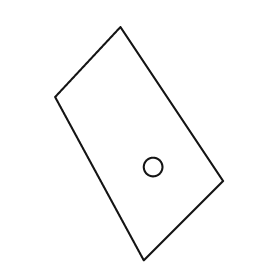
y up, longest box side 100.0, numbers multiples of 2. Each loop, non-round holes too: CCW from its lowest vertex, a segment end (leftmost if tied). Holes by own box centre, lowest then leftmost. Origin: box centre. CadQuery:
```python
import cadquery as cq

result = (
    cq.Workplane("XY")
    .moveTo(2.0, -50.0)
    .lineTo(36.0, -16.0)
    .lineTo(-8.0, 50.0)
    .lineTo(-36.0, 20.0)
    .close()
    .moveTo(6.0, -10.0)
    .circle(4.0)
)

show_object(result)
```